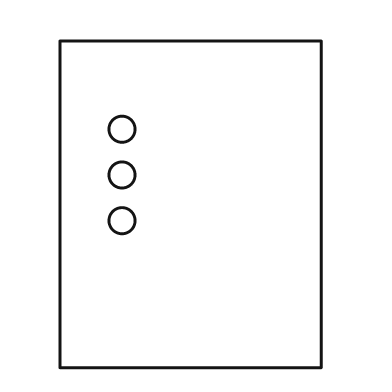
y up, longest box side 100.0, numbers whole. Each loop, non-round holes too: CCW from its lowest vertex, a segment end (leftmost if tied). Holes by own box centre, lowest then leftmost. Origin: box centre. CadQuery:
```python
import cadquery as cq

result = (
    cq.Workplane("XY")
    .moveTo(-40.0, -50.0)
    .lineTo(40.0, -50.0)
    .lineTo(40.0, 50.0)
    .lineTo(-40.0, 50.0)
    .close()
    .moveTo(-21.0, -5.0)
    .circle(4.0)
    .moveTo(-21.0, 9.0)
    .circle(4.0)
    .moveTo(-21.0, 23.0)
    .circle(4.0)
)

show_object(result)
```